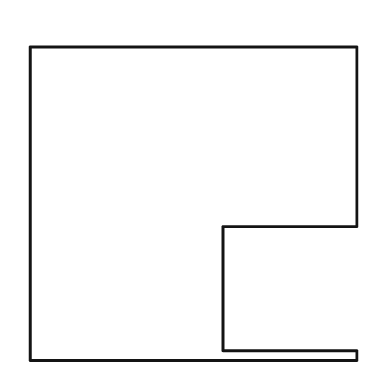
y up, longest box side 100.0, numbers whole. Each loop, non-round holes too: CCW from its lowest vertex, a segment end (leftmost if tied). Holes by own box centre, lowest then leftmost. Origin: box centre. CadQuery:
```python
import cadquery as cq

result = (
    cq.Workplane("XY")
    .moveTo(-50.0, -48.0)
    .lineTo(50.0, -48.0)
    .lineTo(50.0, -45.0)
    .lineTo(9.0, -45.0)
    .lineTo(9.0, -7.0)
    .lineTo(50.0, -7.0)
    .lineTo(50.0, 48.0)
    .lineTo(-50.0, 48.0)
    .close()
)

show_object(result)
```